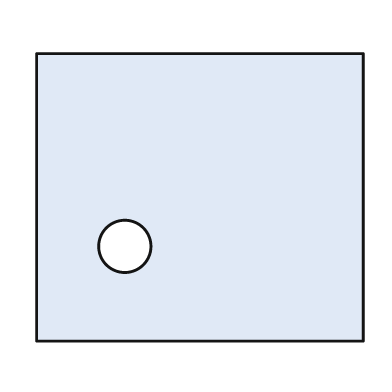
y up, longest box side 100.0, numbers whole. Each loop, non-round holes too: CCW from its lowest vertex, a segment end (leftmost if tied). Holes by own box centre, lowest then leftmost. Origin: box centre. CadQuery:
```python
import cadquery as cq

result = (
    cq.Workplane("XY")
    .moveTo(-50.0, -44.0)
    .lineTo(50.0, -44.0)
    .lineTo(50.0, 44.0)
    .lineTo(-50.0, 44.0)
    .close()
    .moveTo(-23.0, -15.0)
    .circle(8.0)
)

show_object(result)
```